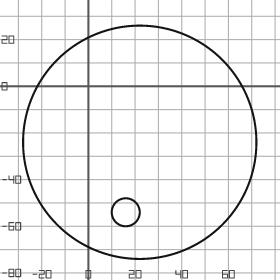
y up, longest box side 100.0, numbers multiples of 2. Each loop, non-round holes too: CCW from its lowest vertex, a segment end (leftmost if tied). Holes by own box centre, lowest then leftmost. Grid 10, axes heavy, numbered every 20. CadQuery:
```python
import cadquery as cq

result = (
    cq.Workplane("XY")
    .moveTo(22.0, -24.0)
    .circle(50.0)
    .moveTo(16.0, -54.0)
    .circle(6.0)
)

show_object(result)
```